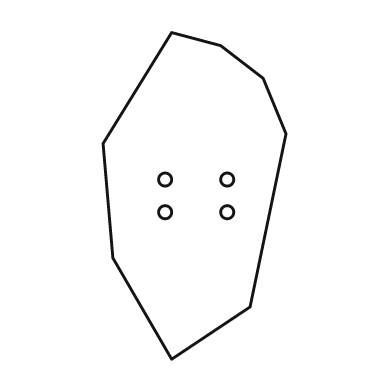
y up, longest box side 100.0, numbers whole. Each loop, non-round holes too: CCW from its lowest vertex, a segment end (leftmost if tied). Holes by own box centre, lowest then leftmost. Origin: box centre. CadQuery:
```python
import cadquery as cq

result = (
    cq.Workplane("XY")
    .moveTo(-7.0, -50.0)
    .lineTo(17.0, -34.0)
    .lineTo(28.0, 19.0)
    .lineTo(21.0, 36.0)
    .lineTo(8.0, 46.0)
    .lineTo(-7.0, 50.0)
    .lineTo(-28.0, 16.0)
    .lineTo(-25.0, -19.0)
    .close()
    .moveTo(-9.0, -5.0)
    .circle(2.0)
    .moveTo(10.0, -5.0)
    .circle(2.0)
    .moveTo(-9.0, 5.0)
    .circle(2.0)
    .moveTo(10.0, 5.0)
    .circle(2.0)
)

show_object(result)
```